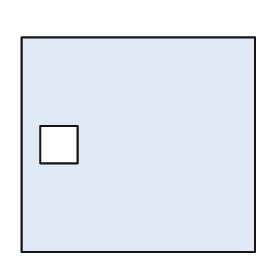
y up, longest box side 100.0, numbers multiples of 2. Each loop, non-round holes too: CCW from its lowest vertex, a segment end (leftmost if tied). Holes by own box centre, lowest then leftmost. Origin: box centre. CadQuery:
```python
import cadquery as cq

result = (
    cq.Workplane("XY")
    .moveTo(-50.0, -46.0)
    .lineTo(50.0, -46.0)
    .lineTo(50.0, 46.0)
    .lineTo(-50.0, 46.0)
    .close()
    .moveTo(-42.0, -8.0)
    .lineTo(-26.0, -8.0)
    .lineTo(-26.0, 8.0)
    .lineTo(-42.0, 8.0)
    .close()
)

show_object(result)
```